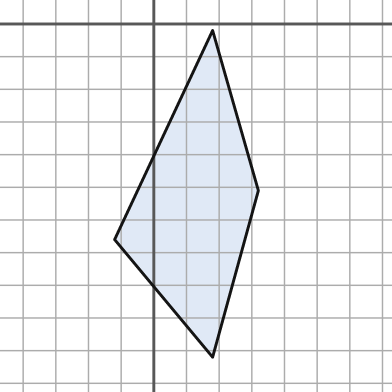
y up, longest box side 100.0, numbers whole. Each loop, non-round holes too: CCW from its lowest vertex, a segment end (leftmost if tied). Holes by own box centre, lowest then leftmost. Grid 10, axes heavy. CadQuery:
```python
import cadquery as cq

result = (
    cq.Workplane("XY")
    .moveTo(18.0, -102.0)
    .lineTo(32.0, -51.0)
    .lineTo(18.0, -2.0)
    .lineTo(-12.0, -66.0)
    .close()
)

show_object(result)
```